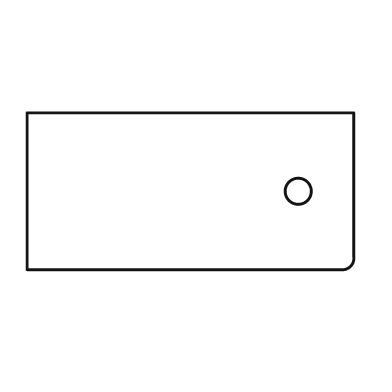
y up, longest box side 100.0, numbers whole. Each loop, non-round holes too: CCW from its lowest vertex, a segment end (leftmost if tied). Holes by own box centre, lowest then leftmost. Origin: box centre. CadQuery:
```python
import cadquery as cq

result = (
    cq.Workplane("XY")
    .moveTo(-50.0, -24.0)
    .lineTo(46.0, -24.0)
    .threePointArc((49.0, -23.0), (50.0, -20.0))
    .lineTo(50.0, 24.0)
    .lineTo(-50.0, 24.0)
    .close()
    .moveTo(33.0, 0.0)
    .circle(4.0)
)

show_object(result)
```